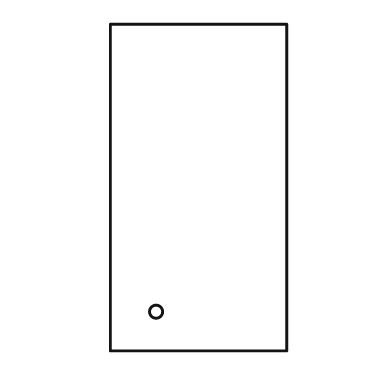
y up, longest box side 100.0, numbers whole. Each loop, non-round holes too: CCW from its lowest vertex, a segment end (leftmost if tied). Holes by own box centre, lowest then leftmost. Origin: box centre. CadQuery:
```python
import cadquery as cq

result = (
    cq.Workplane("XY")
    .moveTo(-27.0, -50.0)
    .lineTo(27.0, -50.0)
    .lineTo(27.0, 50.0)
    .lineTo(-27.0, 50.0)
    .close()
    .moveTo(-13.0, -38.0)
    .circle(2.0)
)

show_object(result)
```